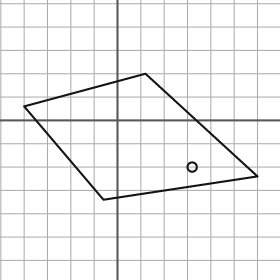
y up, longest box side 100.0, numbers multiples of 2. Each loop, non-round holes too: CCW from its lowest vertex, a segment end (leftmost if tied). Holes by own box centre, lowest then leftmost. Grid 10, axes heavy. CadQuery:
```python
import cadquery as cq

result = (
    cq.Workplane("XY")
    .moveTo(-6.0, -34.0)
    .lineTo(60.0, -24.0)
    .lineTo(12.0, 20.0)
    .lineTo(-40.0, 6.0)
    .close()
    .moveTo(32.0, -20.0)
    .circle(2.0)
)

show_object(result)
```